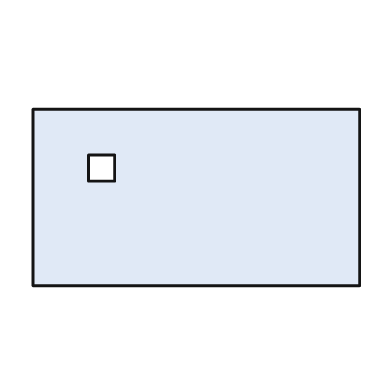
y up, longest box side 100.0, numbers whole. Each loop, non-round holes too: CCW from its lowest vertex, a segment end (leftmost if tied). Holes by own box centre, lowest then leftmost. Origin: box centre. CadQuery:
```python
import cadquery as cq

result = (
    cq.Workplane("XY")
    .moveTo(-50.0, -27.0)
    .lineTo(50.0, -27.0)
    .lineTo(50.0, 27.0)
    .lineTo(-50.0, 27.0)
    .close()
    .moveTo(-33.0, 5.0)
    .lineTo(-25.0, 5.0)
    .lineTo(-25.0, 13.0)
    .lineTo(-33.0, 13.0)
    .close()
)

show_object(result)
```